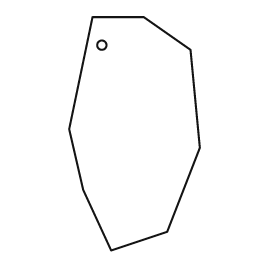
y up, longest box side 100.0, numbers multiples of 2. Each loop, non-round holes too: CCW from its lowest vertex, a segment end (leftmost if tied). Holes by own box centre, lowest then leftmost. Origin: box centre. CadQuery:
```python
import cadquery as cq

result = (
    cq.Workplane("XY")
    .moveTo(-10.0, -50.0)
    .lineTo(14.0, -42.0)
    .lineTo(28.0, -6.0)
    .lineTo(24.0, 36.0)
    .lineTo(4.0, 50.0)
    .lineTo(-18.0, 50.0)
    .lineTo(-28.0, 2.0)
    .lineTo(-22.0, -24.0)
    .close()
    .moveTo(-14.0, 38.0)
    .circle(2.0)
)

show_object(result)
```